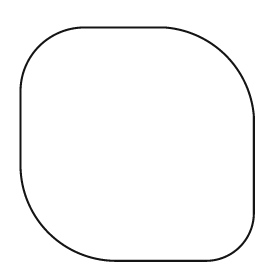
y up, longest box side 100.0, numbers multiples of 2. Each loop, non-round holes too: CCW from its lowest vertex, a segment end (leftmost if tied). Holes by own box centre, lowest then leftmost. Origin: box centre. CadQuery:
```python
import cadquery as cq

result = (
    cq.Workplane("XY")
    .moveTo(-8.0, -50.0)
    .lineTo(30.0, -50.0)
    .threePointArc((44.0, -44.0), (50.0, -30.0))
    .lineTo(50.0, 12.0)
    .threePointArc((38.0, 38.0), (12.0, 50.0))
    .lineTo(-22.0, 50.0)
    .threePointArc((-42.0, 42.0), (-50.0, 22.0))
    .lineTo(-50.0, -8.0)
    .threePointArc((-38.0, -38.0), (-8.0, -50.0))
    .close()
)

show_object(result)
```